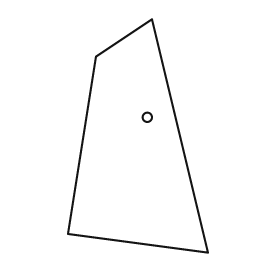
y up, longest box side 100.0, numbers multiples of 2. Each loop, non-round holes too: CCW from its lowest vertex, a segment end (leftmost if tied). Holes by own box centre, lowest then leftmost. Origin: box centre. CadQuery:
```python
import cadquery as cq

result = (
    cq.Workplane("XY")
    .moveTo(30.0, -50.0)
    .lineTo(6.0, 50.0)
    .lineTo(-18.0, 34.0)
    .lineTo(-30.0, -42.0)
    .close()
    .moveTo(4.0, 8.0)
    .circle(2.0)
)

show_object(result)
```